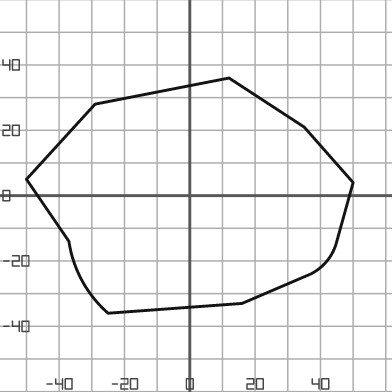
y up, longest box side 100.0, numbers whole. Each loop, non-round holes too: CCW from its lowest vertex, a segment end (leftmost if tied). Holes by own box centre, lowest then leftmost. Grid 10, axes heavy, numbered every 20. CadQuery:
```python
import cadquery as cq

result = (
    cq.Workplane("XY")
    .moveTo(-25.0, -36.0)
    .lineTo(16.0, -33.0)
    .lineTo(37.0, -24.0)
    .threePointArc((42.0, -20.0), (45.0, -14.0))
    .lineTo(50.0, 4.0)
    .lineTo(35.0, 21.0)
    .lineTo(12.0, 36.0)
    .lineTo(-29.0, 28.0)
    .lineTo(-50.0, 5.0)
    .lineTo(-37.0, -14.0)
    .threePointArc((-33.0, -26.0), (-25.0, -36.0))
    .close()
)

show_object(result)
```